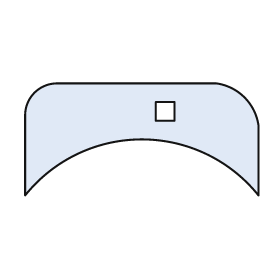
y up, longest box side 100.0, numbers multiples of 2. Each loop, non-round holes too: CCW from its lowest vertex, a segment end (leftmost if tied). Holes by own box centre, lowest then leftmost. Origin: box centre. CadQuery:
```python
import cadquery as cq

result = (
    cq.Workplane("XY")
    .moveTo(-50.0, -24.0)
    .threePointArc((0.0, 0.0), (50.0, -24.0))
    .lineTo(50.0, 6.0)
    .threePointArc((44.0, 18.0), (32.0, 24.0))
    .lineTo(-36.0, 24.0)
    .threePointArc((-46.0, 20.0), (-50.0, 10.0))
    .close()
    .moveTo(6.0, 8.0)
    .lineTo(14.0, 8.0)
    .lineTo(14.0, 16.0)
    .lineTo(6.0, 16.0)
    .close()
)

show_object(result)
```